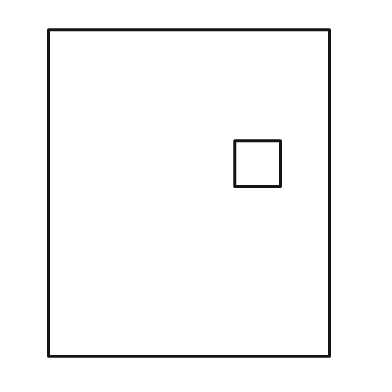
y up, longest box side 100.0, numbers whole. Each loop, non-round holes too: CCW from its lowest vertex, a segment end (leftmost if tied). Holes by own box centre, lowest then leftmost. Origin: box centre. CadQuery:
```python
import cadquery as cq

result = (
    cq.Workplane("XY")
    .moveTo(-43.0, -50.0)
    .lineTo(43.0, -50.0)
    .lineTo(43.0, 50.0)
    .lineTo(-43.0, 50.0)
    .close()
    .moveTo(14.0, 2.0)
    .lineTo(28.0, 2.0)
    .lineTo(28.0, 16.0)
    .lineTo(14.0, 16.0)
    .close()
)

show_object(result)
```